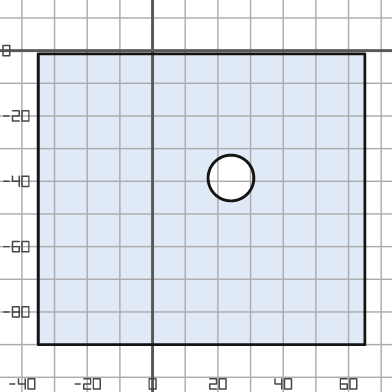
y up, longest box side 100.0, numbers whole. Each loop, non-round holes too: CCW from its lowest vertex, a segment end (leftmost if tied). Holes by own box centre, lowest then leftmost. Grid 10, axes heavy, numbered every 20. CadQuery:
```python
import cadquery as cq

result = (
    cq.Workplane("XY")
    .moveTo(-35.0, -90.0)
    .lineTo(65.0, -90.0)
    .lineTo(65.0, -1.0)
    .lineTo(-35.0, -1.0)
    .close()
    .moveTo(24.0, -39.0)
    .circle(7.0)
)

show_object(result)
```